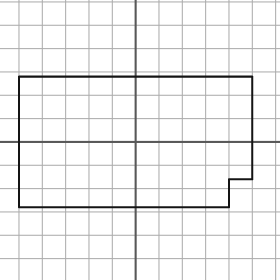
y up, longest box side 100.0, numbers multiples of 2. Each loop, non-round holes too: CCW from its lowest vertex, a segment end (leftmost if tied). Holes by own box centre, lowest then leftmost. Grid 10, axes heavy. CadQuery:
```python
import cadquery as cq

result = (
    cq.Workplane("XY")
    .moveTo(-50.0, -28.0)
    .lineTo(40.0, -28.0)
    .lineTo(40.0, -16.0)
    .lineTo(50.0, -16.0)
    .lineTo(50.0, 28.0)
    .lineTo(-50.0, 28.0)
    .close()
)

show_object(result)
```